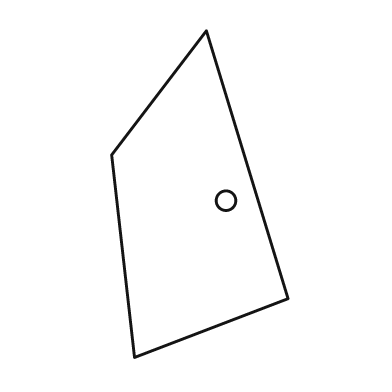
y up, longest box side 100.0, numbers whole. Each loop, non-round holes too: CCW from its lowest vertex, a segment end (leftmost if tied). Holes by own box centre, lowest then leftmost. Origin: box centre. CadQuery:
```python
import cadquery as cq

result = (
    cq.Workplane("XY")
    .moveTo(-20.0, -50.0)
    .lineTo(27.0, -32.0)
    .lineTo(2.0, 50.0)
    .lineTo(-27.0, 12.0)
    .close()
    .moveTo(8.0, -2.0)
    .circle(3.0)
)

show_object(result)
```